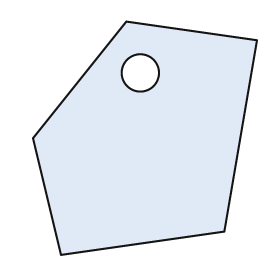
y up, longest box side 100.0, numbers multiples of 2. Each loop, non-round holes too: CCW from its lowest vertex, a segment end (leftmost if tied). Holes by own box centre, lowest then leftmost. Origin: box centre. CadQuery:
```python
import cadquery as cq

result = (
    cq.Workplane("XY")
    .moveTo(-36.0, -50.0)
    .lineTo(34.0, -40.0)
    .lineTo(48.0, 42.0)
    .lineTo(-8.0, 50.0)
    .lineTo(-48.0, 0.0)
    .close()
    .moveTo(-2.0, 28.0)
    .circle(8.0)
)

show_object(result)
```